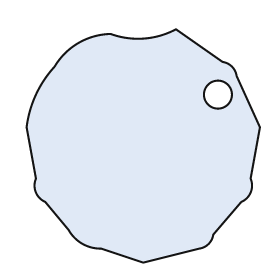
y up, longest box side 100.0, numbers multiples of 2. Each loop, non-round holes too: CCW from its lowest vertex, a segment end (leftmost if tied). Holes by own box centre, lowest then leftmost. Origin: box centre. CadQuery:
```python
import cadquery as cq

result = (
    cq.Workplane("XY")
    .moveTo(0.0, -50.0)
    .lineTo(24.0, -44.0)
    .threePointArc((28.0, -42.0), (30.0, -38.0))
    .lineTo(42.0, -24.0)
    .threePointArc((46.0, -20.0), (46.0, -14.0))
    .lineTo(50.0, 8.0)
    .lineTo(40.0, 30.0)
    .threePointArc((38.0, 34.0), (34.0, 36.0))
    .lineTo(14.0, 50.0)
    .threePointArc((0.0, 46.0), (-14.0, 48.0))
    .threePointArc((-28.0, 44.0), (-38.0, 34.0))
    .threePointArc((-46.0, 22.0), (-50.0, 8.0))
    .lineTo(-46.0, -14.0)
    .threePointArc((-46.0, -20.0), (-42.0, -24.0))
    .lineTo(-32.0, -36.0)
    .threePointArc((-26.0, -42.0), (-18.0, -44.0))
    .close()
    .moveTo(32.0, 22.0)
    .circle(6.0)
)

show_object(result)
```